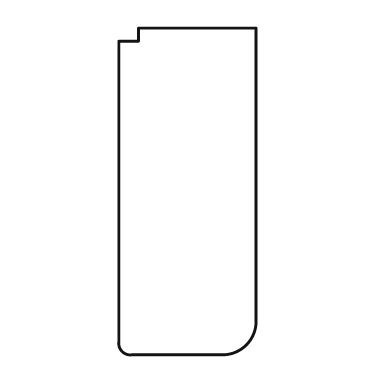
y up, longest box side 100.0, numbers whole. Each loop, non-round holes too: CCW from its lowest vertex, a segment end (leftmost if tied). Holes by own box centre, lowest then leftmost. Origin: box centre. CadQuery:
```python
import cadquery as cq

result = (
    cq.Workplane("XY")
    .moveTo(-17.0, -50.0)
    .lineTo(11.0, -50.0)
    .threePointArc((18.0, -47.0), (21.0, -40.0))
    .lineTo(21.0, 50.0)
    .lineTo(-15.0, 50.0)
    .lineTo(-15.0, 46.0)
    .lineTo(-21.0, 46.0)
    .lineTo(-21.0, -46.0)
    .threePointArc((-20.0, -49.0), (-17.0, -50.0))
    .close()
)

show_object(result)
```